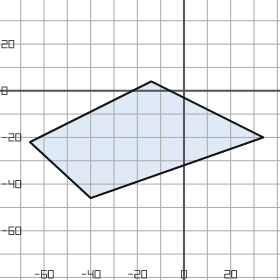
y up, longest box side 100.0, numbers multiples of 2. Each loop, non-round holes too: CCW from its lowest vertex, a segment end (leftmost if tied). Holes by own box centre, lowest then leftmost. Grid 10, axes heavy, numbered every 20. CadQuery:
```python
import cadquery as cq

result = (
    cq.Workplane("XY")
    .moveTo(-40.0, -46.0)
    .lineTo(34.0, -20.0)
    .lineTo(-14.0, 4.0)
    .lineTo(-66.0, -22.0)
    .close()
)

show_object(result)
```